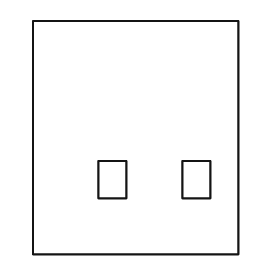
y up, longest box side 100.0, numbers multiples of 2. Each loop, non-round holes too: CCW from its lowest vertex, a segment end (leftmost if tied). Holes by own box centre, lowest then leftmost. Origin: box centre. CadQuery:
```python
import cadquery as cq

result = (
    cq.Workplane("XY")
    .moveTo(-44.0, -50.0)
    .lineTo(44.0, -50.0)
    .lineTo(44.0, 50.0)
    .lineTo(-44.0, 50.0)
    .close()
    .moveTo(-16.0, -26.0)
    .lineTo(-4.0, -26.0)
    .lineTo(-4.0, -10.0)
    .lineTo(-16.0, -10.0)
    .close()
    .moveTo(20.0, -26.0)
    .lineTo(32.0, -26.0)
    .lineTo(32.0, -10.0)
    .lineTo(20.0, -10.0)
    .close()
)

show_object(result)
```